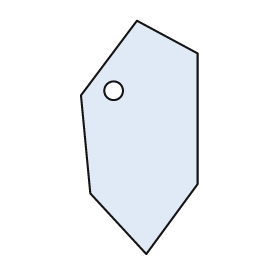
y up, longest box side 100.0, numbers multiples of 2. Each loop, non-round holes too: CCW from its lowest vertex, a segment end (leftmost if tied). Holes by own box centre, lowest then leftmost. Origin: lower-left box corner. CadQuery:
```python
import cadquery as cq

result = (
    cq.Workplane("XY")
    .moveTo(28.0, 0.0)
    .lineTo(50.0, 30.0)
    .lineTo(50.0, 86.0)
    .lineTo(24.0, 100.0)
    .lineTo(0.0, 68.0)
    .lineTo(4.0, 26.0)
    .close()
    .moveTo(14.0, 70.0)
    .circle(4.0)
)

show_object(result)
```